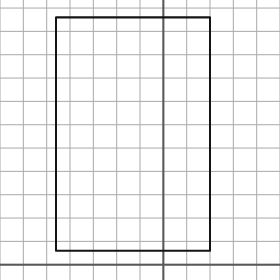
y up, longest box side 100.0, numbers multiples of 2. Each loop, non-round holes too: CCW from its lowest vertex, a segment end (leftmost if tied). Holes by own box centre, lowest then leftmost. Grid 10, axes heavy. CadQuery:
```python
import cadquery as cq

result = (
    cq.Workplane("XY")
    .moveTo(-46.0, 6.0)
    .lineTo(20.0, 6.0)
    .lineTo(20.0, 106.0)
    .lineTo(-46.0, 106.0)
    .close()
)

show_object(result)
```